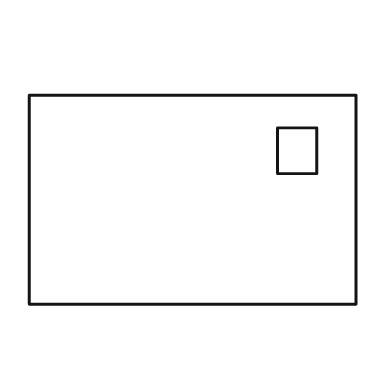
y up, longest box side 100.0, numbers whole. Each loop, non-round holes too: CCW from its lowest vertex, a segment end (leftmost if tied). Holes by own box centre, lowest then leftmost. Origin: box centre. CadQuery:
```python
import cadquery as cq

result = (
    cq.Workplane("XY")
    .moveTo(-50.0, -32.0)
    .lineTo(50.0, -32.0)
    .lineTo(50.0, 32.0)
    .lineTo(-50.0, 32.0)
    .close()
    .moveTo(26.0, 8.0)
    .lineTo(38.0, 8.0)
    .lineTo(38.0, 22.0)
    .lineTo(26.0, 22.0)
    .close()
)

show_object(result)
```